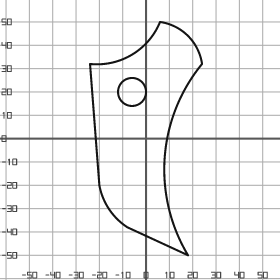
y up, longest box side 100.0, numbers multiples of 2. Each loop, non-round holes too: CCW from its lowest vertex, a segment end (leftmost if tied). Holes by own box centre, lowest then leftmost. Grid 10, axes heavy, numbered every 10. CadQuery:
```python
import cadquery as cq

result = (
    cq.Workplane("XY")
    .moveTo(18.0, -50.0)
    .threePointArc((8.0, -8.0), (24.0, 32.0))
    .threePointArc((18.0, 44.0), (6.0, 50.0))
    .threePointArc((-6.0, 36.0), (-24.0, 32.0))
    .lineTo(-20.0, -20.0)
    .threePointArc((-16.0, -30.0), (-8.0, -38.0))
    .close()
    .moveTo(-6.0, 20.0)
    .circle(6.0)
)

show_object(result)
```